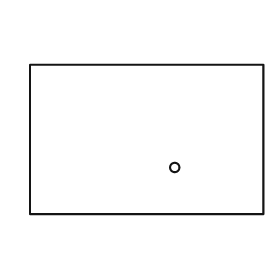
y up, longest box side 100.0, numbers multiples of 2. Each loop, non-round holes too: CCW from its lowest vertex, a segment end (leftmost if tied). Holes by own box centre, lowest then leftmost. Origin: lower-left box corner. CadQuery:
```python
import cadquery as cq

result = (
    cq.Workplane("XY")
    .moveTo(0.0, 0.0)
    .lineTo(100.0, 0.0)
    .lineTo(100.0, 64.0)
    .lineTo(0.0, 64.0)
    .close()
    .moveTo(62.0, 20.0)
    .circle(2.0)
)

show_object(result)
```